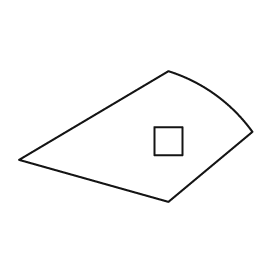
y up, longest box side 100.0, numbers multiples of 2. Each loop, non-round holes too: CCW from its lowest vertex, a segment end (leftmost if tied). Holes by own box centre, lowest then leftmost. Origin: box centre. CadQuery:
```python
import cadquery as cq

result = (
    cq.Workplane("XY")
    .moveTo(14.0, -28.0)
    .lineTo(50.0, 2.0)
    .threePointArc((34.0, 18.0), (14.0, 28.0))
    .lineTo(-50.0, -10.0)
    .close()
    .moveTo(8.0, -8.0)
    .lineTo(20.0, -8.0)
    .lineTo(20.0, 4.0)
    .lineTo(8.0, 4.0)
    .close()
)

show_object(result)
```